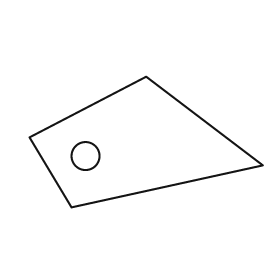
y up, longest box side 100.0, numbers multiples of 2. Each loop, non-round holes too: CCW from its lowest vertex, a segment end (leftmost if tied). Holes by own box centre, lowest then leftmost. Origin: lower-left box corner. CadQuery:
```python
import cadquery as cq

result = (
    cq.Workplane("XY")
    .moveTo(18.0, 0.0)
    .lineTo(100.0, 18.0)
    .lineTo(50.0, 56.0)
    .lineTo(0.0, 30.0)
    .close()
    .moveTo(24.0, 22.0)
    .circle(6.0)
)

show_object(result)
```